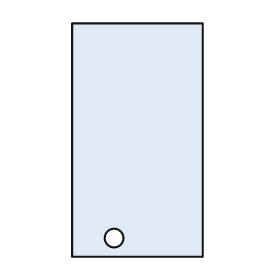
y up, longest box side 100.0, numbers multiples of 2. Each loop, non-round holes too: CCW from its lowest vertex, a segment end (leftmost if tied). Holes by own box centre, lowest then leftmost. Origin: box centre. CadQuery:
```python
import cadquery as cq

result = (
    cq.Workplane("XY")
    .moveTo(-28.0, -50.0)
    .lineTo(28.0, -50.0)
    .lineTo(28.0, 50.0)
    .lineTo(-28.0, 50.0)
    .close()
    .moveTo(-10.0, -42.0)
    .circle(4.0)
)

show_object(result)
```